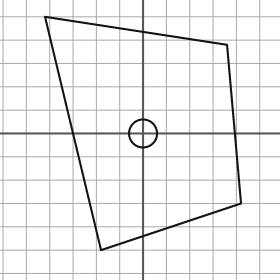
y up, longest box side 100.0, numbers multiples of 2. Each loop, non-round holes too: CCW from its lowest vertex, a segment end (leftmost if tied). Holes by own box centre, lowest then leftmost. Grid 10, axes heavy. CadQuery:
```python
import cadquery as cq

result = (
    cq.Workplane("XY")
    .moveTo(-18.0, -50.0)
    .lineTo(42.0, -30.0)
    .lineTo(36.0, 38.0)
    .lineTo(-42.0, 50.0)
    .close()
    .moveTo(0.0, 0.0)
    .circle(6.0)
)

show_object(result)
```